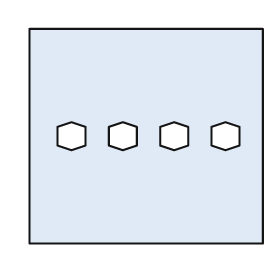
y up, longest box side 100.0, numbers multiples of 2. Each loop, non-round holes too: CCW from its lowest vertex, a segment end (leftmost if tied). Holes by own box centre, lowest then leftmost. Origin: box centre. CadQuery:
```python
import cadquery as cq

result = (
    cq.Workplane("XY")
    .moveTo(-50.0, -46.0)
    .lineTo(50.0, -46.0)
    .lineTo(50.0, 46.0)
    .lineTo(-50.0, 46.0)
    .close()
    .moveTo(-32.0, -6.0)
    .lineTo(-26.0, -4.0)
    .lineTo(-26.0, 4.0)
    .lineTo(-32.0, 6.0)
    .lineTo(-38.0, 4.0)
    .lineTo(-38.0, -4.0)
    .close()
    .moveTo(-10.0, -6.0)
    .lineTo(-4.0, -4.0)
    .lineTo(-4.0, 4.0)
    .lineTo(-10.0, 6.0)
    .lineTo(-16.0, 4.0)
    .lineTo(-16.0, -4.0)
    .close()
    .moveTo(12.0, -6.0)
    .lineTo(18.0, -4.0)
    .lineTo(18.0, 4.0)
    .lineTo(12.0, 6.0)
    .lineTo(6.0, 4.0)
    .lineTo(6.0, -4.0)
    .close()
    .moveTo(34.0, -6.0)
    .lineTo(40.0, -4.0)
    .lineTo(40.0, 4.0)
    .lineTo(34.0, 6.0)
    .lineTo(28.0, 4.0)
    .lineTo(28.0, -4.0)
    .close()
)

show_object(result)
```